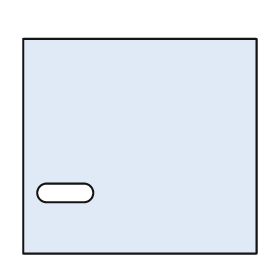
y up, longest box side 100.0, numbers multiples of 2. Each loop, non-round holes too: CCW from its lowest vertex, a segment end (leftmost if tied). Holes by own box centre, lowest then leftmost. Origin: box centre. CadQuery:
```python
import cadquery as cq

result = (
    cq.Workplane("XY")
    .moveTo(-50.0, -46.0)
    .lineTo(50.0, -46.0)
    .lineTo(50.0, 46.0)
    .lineTo(-50.0, 46.0)
    .close()
    .moveTo(-40.0, -24.0)
    .lineTo(-24.0, -24.0)
    .threePointArc((-20.0, -20.0), (-24.0, -16.0))
    .lineTo(-40.0, -16.0)
    .threePointArc((-44.0, -20.0), (-40.0, -24.0))
    .close()
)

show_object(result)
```